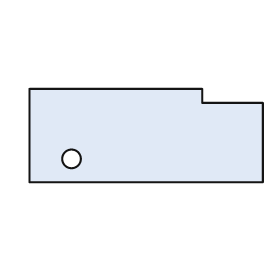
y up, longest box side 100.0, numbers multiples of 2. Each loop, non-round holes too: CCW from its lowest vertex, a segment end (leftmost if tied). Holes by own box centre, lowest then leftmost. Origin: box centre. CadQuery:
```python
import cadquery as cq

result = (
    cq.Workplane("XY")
    .moveTo(-50.0, -20.0)
    .lineTo(50.0, -20.0)
    .lineTo(50.0, 14.0)
    .lineTo(24.0, 14.0)
    .lineTo(24.0, 20.0)
    .lineTo(-50.0, 20.0)
    .close()
    .moveTo(-32.0, -10.0)
    .circle(4.0)
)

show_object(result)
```